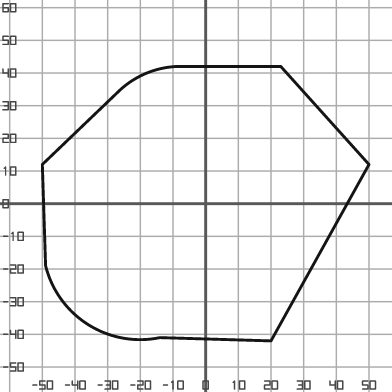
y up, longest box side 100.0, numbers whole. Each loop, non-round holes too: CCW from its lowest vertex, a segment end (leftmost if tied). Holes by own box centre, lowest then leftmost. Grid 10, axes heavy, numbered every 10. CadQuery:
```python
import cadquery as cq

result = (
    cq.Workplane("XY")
    .moveTo(20.0, -42.0)
    .lineTo(50.0, 12.0)
    .lineTo(23.0, 42.0)
    .lineTo(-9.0, 42.0)
    .threePointArc((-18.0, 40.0), (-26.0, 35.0))
    .lineTo(-50.0, 12.0)
    .lineTo(-49.0, -19.0)
    .threePointArc((-36.0, -37.0), (-14.0, -41.0))
    .close()
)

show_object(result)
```